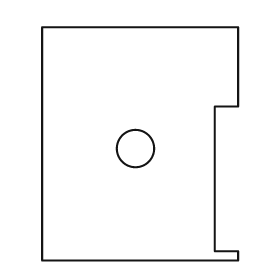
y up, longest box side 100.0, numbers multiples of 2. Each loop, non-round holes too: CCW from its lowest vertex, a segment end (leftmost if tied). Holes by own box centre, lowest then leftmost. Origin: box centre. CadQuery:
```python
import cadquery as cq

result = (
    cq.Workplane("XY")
    .moveTo(-42.0, -50.0)
    .lineTo(42.0, -50.0)
    .lineTo(42.0, -46.0)
    .lineTo(32.0, -46.0)
    .lineTo(32.0, 16.0)
    .lineTo(42.0, 16.0)
    .lineTo(42.0, 50.0)
    .lineTo(-42.0, 50.0)
    .close()
    .moveTo(-2.0, -2.0)
    .circle(8.0)
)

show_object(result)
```